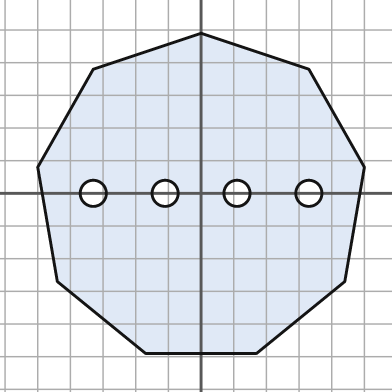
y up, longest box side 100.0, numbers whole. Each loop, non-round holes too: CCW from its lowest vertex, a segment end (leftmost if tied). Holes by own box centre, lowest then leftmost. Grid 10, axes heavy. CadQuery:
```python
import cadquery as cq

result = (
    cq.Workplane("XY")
    .moveTo(-17.0, -49.0)
    .lineTo(17.0, -49.0)
    .lineTo(44.0, -27.0)
    .lineTo(50.0, 8.0)
    .lineTo(33.0, 38.0)
    .lineTo(0.0, 49.0)
    .lineTo(-33.0, 38.0)
    .lineTo(-50.0, 8.0)
    .lineTo(-44.0, -27.0)
    .close()
    .moveTo(-33.0, 0.0)
    .circle(4.0)
    .moveTo(-11.0, 0.0)
    .circle(4.0)
    .moveTo(11.0, 0.0)
    .circle(4.0)
    .moveTo(33.0, 0.0)
    .circle(4.0)
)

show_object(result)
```